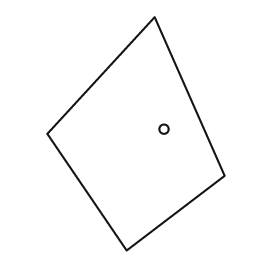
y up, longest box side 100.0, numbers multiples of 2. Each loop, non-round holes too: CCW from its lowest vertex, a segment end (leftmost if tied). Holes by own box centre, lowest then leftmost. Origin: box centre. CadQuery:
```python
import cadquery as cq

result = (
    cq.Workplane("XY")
    .moveTo(-4.0, -50.0)
    .lineTo(38.0, -18.0)
    .lineTo(8.0, 50.0)
    .lineTo(-38.0, 0.0)
    .close()
    .moveTo(12.0, 2.0)
    .circle(2.0)
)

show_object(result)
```